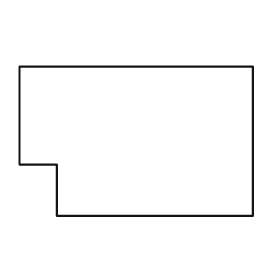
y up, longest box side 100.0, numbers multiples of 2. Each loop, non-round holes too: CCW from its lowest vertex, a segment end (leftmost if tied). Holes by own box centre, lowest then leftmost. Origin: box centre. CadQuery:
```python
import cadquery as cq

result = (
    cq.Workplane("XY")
    .moveTo(-34.0, -32.0)
    .lineTo(50.0, -32.0)
    .lineTo(50.0, 32.0)
    .lineTo(-50.0, 32.0)
    .lineTo(-50.0, -10.0)
    .lineTo(-34.0, -10.0)
    .close()
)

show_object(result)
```